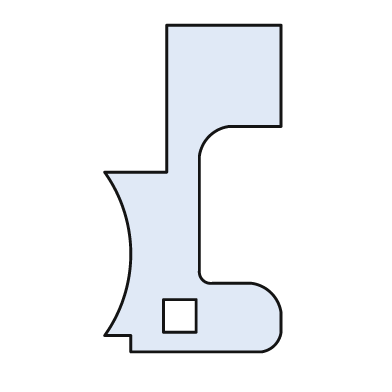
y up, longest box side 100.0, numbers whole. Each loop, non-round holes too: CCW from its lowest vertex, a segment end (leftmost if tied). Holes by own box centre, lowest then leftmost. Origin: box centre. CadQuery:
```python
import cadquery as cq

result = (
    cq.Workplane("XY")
    .moveTo(-19.0, -50.0)
    .lineTo(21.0, -50.0)
    .threePointArc((25.0, -48.0), (27.0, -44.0))
    .lineTo(27.0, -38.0)
    .threePointArc((24.0, -32.0), (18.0, -29.0))
    .lineTo(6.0, -29.0)
    .threePointArc((3.0, -28.0), (2.0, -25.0))
    .lineTo(2.0, 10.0)
    .threePointArc((5.0, 16.0), (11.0, 19.0))
    .lineTo(27.0, 19.0)
    .lineTo(27.0, 50.0)
    .lineTo(-8.0, 50.0)
    .lineTo(-8.0, 5.0)
    .lineTo(-27.0, 5.0)
    .threePointArc((-19.0, -20.0), (-27.0, -45.0))
    .lineTo(-19.0, -45.0)
    .close()
    .moveTo(-9.0, -44.0)
    .lineTo(1.0, -44.0)
    .lineTo(1.0, -34.0)
    .lineTo(-9.0, -34.0)
    .close()
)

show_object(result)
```